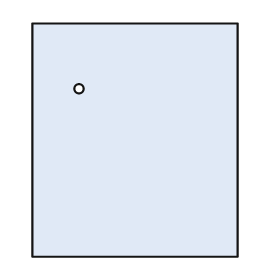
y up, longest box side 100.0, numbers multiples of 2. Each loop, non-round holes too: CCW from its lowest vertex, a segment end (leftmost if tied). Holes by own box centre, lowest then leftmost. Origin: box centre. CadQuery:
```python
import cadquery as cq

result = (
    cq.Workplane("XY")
    .moveTo(-44.0, -50.0)
    .lineTo(44.0, -50.0)
    .lineTo(44.0, 50.0)
    .lineTo(-44.0, 50.0)
    .close()
    .moveTo(-24.0, 22.0)
    .circle(2.0)
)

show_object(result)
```